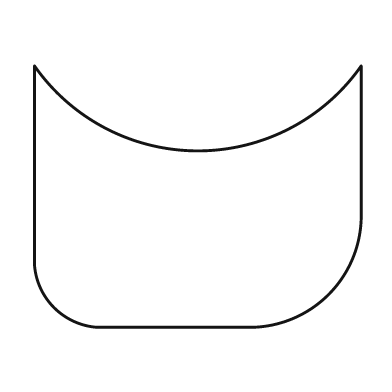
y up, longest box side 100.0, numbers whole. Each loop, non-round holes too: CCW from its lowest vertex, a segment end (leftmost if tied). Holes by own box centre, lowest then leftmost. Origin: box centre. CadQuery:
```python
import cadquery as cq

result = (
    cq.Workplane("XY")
    .moveTo(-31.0, -40.0)
    .lineTo(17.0, -40.0)
    .threePointArc((40.0, -30.0), (50.0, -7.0))
    .lineTo(50.0, 40.0)
    .threePointArc((0.0, 14.0), (-50.0, 40.0))
    .lineTo(-50.0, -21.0)
    .threePointArc((-44.0, -34.0), (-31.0, -40.0))
    .close()
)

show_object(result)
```